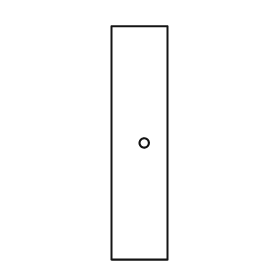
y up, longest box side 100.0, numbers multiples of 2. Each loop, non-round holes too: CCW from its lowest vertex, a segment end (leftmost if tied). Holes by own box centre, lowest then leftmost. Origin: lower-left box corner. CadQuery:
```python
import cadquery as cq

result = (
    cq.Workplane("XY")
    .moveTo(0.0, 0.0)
    .lineTo(24.0, 0.0)
    .lineTo(24.0, 100.0)
    .lineTo(0.0, 100.0)
    .close()
    .moveTo(14.0, 50.0)
    .circle(2.0)
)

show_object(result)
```